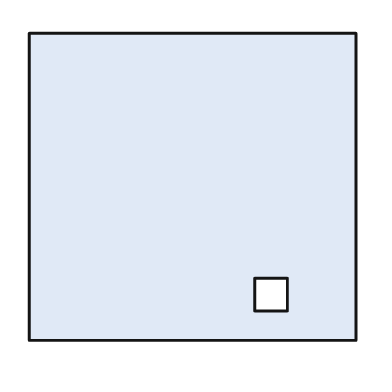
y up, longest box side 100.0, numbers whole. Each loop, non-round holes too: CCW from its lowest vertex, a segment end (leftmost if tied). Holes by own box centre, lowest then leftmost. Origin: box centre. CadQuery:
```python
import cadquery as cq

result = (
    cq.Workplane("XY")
    .moveTo(-50.0, -47.0)
    .lineTo(50.0, -47.0)
    .lineTo(50.0, 47.0)
    .lineTo(-50.0, 47.0)
    .close()
    .moveTo(19.0, -38.0)
    .lineTo(29.0, -38.0)
    .lineTo(29.0, -28.0)
    .lineTo(19.0, -28.0)
    .close()
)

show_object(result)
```